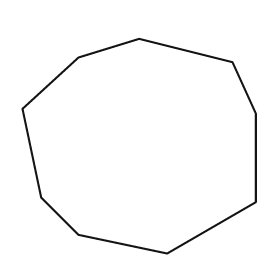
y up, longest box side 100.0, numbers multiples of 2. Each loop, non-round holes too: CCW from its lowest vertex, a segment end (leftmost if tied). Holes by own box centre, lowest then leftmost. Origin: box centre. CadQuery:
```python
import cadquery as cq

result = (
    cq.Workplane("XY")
    .moveTo(12.0, -46.0)
    .lineTo(50.0, -24.0)
    .lineTo(50.0, 14.0)
    .lineTo(40.0, 36.0)
    .lineTo(0.0, 46.0)
    .lineTo(-26.0, 38.0)
    .lineTo(-50.0, 16.0)
    .lineTo(-42.0, -22.0)
    .lineTo(-26.0, -38.0)
    .close()
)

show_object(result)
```